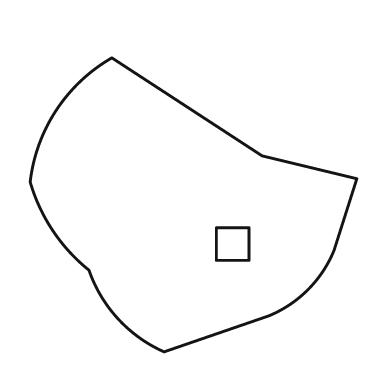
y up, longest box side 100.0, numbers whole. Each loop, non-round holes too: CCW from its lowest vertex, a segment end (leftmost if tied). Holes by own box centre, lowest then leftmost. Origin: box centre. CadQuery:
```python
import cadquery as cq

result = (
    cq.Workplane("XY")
    .moveTo(-9.0, -45.0)
    .lineTo(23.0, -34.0)
    .threePointArc((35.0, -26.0), (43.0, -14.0))
    .lineTo(50.0, 8.0)
    .lineTo(21.0, 15.0)
    .lineTo(-25.0, 45.0)
    .threePointArc((-42.0, 29.0), (-50.0, 7.0))
    .threePointArc((-43.0, -8.0), (-32.0, -20.0))
    .threePointArc((-23.0, -35.0), (-9.0, -45.0))
    .close()
    .moveTo(7.0, -17.0)
    .lineTo(17.0, -17.0)
    .lineTo(17.0, -7.0)
    .lineTo(7.0, -7.0)
    .close()
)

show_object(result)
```